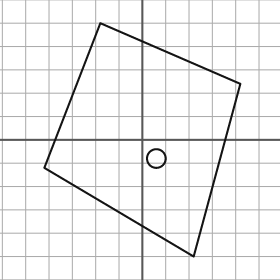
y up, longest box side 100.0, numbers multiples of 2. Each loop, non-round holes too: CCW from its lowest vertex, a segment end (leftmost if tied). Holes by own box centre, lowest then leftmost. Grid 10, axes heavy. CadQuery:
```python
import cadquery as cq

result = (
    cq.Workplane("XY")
    .moveTo(22.0, -50.0)
    .lineTo(42.0, 24.0)
    .lineTo(-18.0, 50.0)
    .lineTo(-42.0, -12.0)
    .close()
    .moveTo(6.0, -8.0)
    .circle(4.0)
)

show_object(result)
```